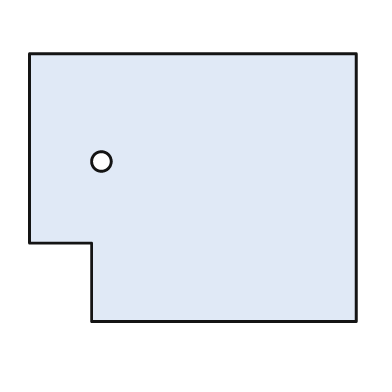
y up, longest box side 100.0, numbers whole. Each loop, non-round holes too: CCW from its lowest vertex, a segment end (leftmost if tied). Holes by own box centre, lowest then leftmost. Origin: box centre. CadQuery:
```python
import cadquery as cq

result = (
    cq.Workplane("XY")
    .moveTo(-31.0, -41.0)
    .lineTo(50.0, -41.0)
    .lineTo(50.0, 41.0)
    .lineTo(-50.0, 41.0)
    .lineTo(-50.0, -17.0)
    .lineTo(-31.0, -17.0)
    .close()
    .moveTo(-28.0, 8.0)
    .circle(3.0)
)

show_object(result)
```